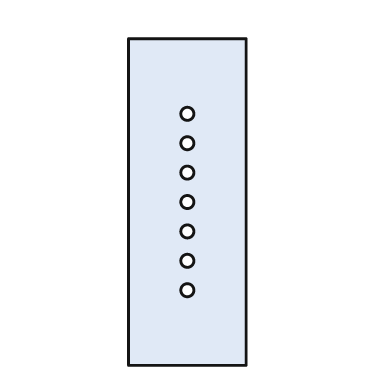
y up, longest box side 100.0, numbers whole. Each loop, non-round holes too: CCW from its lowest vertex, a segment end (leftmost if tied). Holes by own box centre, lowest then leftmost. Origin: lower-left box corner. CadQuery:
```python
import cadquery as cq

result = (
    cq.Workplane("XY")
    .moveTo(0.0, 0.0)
    .lineTo(36.0, 0.0)
    .lineTo(36.0, 100.0)
    .lineTo(0.0, 100.0)
    .close()
    .moveTo(18.0, 23.0)
    .circle(2.0)
    .moveTo(18.0, 32.0)
    .circle(2.0)
    .moveTo(18.0, 41.0)
    .circle(2.0)
    .moveTo(18.0, 50.0)
    .circle(2.0)
    .moveTo(18.0, 59.0)
    .circle(2.0)
    .moveTo(18.0, 68.0)
    .circle(2.0)
    .moveTo(18.0, 77.0)
    .circle(2.0)
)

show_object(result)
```